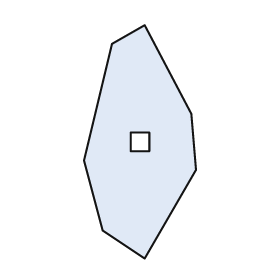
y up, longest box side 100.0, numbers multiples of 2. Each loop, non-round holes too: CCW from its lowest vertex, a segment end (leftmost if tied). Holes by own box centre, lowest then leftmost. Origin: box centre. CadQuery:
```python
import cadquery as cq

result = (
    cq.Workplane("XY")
    .moveTo(2.0, -50.0)
    .lineTo(24.0, -12.0)
    .lineTo(22.0, 12.0)
    .lineTo(2.0, 50.0)
    .lineTo(-12.0, 42.0)
    .lineTo(-24.0, -8.0)
    .lineTo(-16.0, -38.0)
    .close()
    .moveTo(-4.0, -4.0)
    .lineTo(4.0, -4.0)
    .lineTo(4.0, 4.0)
    .lineTo(-4.0, 4.0)
    .close()
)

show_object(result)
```